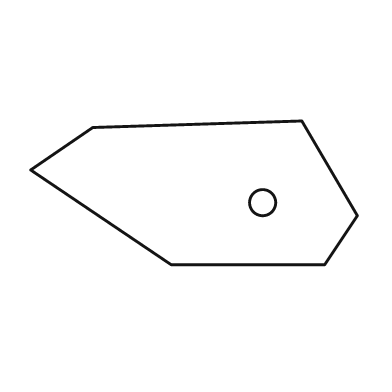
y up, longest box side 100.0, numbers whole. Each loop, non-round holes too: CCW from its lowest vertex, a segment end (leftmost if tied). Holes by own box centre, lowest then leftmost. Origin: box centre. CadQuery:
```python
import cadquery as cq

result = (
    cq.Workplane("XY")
    .moveTo(-7.0, -22.0)
    .lineTo(40.0, -22.0)
    .lineTo(50.0, -7.0)
    .lineTo(33.0, 22.0)
    .lineTo(-31.0, 20.0)
    .lineTo(-50.0, 7.0)
    .close()
    .moveTo(21.0, -3.0)
    .circle(4.0)
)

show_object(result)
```